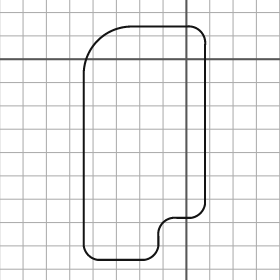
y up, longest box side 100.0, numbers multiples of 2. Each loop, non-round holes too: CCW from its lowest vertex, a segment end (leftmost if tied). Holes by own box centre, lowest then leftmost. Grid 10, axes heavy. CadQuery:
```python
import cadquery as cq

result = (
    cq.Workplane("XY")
    .moveTo(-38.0, -86.0)
    .lineTo(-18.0, -86.0)
    .threePointArc((-14.0, -84.0), (-12.0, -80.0))
    .lineTo(-12.0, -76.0)
    .threePointArc((-10.0, -70.0), (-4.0, -68.0))
    .lineTo(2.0, -68.0)
    .threePointArc((6.0, -66.0), (8.0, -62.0))
    .lineTo(8.0, 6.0)
    .threePointArc((6.0, 12.0), (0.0, 14.0))
    .lineTo(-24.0, 14.0)
    .threePointArc((-38.0, 8.0), (-44.0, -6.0))
    .lineTo(-44.0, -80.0)
    .threePointArc((-42.0, -84.0), (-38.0, -86.0))
    .close()
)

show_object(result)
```